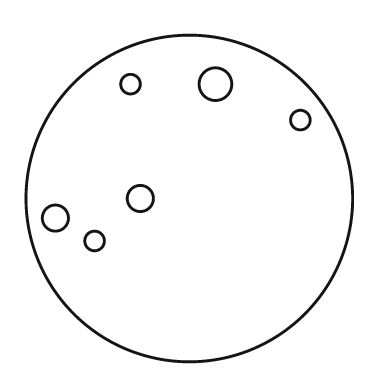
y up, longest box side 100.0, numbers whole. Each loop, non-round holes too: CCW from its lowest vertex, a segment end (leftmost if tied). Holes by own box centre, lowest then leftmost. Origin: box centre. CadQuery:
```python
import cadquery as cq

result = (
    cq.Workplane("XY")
    .moveTo(0.0, 0.0)
    .circle(50.0)
    .moveTo(-29.0, -13.0)
    .circle(3.0)
    .moveTo(-41.0, -6.0)
    .circle(4.0)
    .moveTo(-15.0, 0.0)
    .circle(4.0)
    .moveTo(34.0, 24.0)
    .circle(3.0)
    .moveTo(-18.0, 35.0)
    .circle(3.0)
    .moveTo(8.0, 35.0)
    .circle(5.0)
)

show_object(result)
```